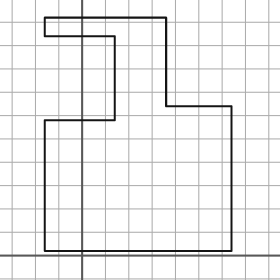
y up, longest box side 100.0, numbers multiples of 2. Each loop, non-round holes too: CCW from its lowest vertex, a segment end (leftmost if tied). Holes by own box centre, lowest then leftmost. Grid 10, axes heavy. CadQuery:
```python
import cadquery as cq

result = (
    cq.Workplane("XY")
    .moveTo(-16.0, 2.0)
    .lineTo(64.0, 2.0)
    .lineTo(64.0, 64.0)
    .lineTo(36.0, 64.0)
    .lineTo(36.0, 102.0)
    .lineTo(-16.0, 102.0)
    .lineTo(-16.0, 94.0)
    .lineTo(14.0, 94.0)
    .lineTo(14.0, 58.0)
    .lineTo(-16.0, 58.0)
    .close()
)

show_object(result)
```